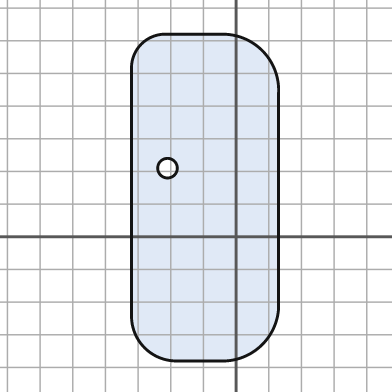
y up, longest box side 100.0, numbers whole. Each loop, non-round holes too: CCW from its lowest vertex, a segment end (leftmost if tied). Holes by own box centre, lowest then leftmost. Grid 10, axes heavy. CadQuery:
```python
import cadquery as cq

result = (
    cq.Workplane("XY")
    .moveTo(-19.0, -38.0)
    .lineTo(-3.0, -38.0)
    .threePointArc((8.0, -33.0), (13.0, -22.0))
    .lineTo(13.0, 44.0)
    .threePointArc((8.0, 57.0), (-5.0, 62.0))
    .lineTo(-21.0, 62.0)
    .threePointArc((-29.0, 59.0), (-32.0, 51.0))
    .lineTo(-32.0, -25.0)
    .threePointArc((-28.0, -34.0), (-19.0, -38.0))
    .close()
    .moveTo(-21.0, 21.0)
    .circle(3.0)
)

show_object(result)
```